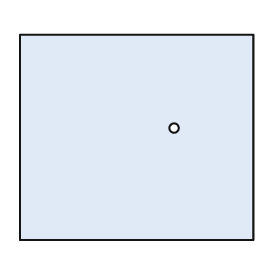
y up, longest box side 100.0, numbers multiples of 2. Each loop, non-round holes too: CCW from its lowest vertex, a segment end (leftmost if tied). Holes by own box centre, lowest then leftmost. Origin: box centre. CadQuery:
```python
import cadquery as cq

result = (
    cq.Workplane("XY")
    .moveTo(-50.0, -44.0)
    .lineTo(50.0, -44.0)
    .lineTo(50.0, 44.0)
    .lineTo(-50.0, 44.0)
    .close()
    .moveTo(16.0, 4.0)
    .circle(2.0)
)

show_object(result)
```